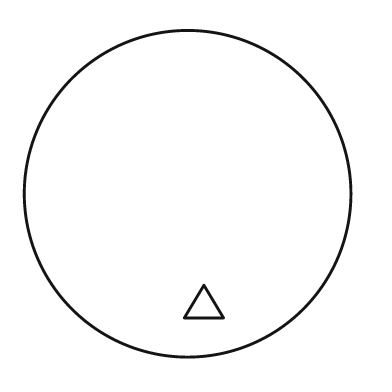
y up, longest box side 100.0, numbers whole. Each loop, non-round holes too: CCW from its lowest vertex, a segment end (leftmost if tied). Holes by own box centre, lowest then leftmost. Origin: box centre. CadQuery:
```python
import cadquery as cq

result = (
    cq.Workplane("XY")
    .moveTo(0.0, 0.0)
    .circle(50.0)
    .moveTo(-1.0, -38.0)
    .lineTo(11.0, -38.0)
    .lineTo(5.0, -28.0)
    .close()
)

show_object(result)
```